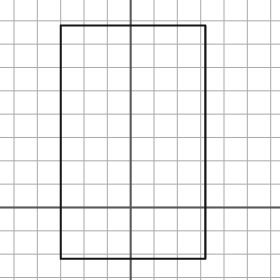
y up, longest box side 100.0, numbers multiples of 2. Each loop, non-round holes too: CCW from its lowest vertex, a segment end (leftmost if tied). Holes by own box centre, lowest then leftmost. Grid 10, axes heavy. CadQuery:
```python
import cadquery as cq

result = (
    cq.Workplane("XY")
    .moveTo(-30.0, -22.0)
    .lineTo(32.0, -22.0)
    .lineTo(32.0, 78.0)
    .lineTo(-30.0, 78.0)
    .close()
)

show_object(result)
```